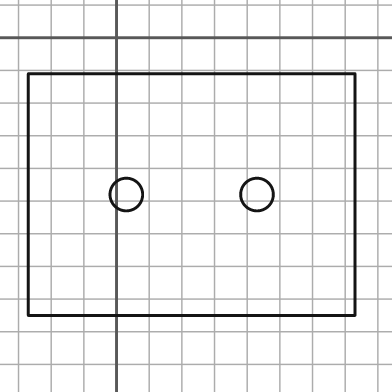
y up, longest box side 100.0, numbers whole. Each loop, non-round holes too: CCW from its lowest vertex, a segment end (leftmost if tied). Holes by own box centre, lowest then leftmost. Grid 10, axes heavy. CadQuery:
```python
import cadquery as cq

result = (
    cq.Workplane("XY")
    .moveTo(-27.0, -85.0)
    .lineTo(73.0, -85.0)
    .lineTo(73.0, -11.0)
    .lineTo(-27.0, -11.0)
    .close()
    .moveTo(3.0, -48.0)
    .circle(5.0)
    .moveTo(43.0, -48.0)
    .circle(5.0)
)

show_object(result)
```